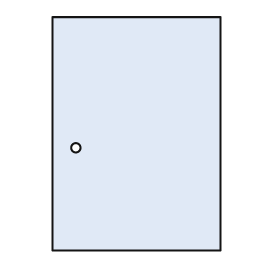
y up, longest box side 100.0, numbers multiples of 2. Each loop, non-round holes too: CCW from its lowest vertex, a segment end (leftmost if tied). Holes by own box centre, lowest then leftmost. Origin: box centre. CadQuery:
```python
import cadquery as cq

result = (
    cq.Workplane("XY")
    .moveTo(-36.0, -50.0)
    .lineTo(36.0, -50.0)
    .lineTo(36.0, 50.0)
    .lineTo(-36.0, 50.0)
    .close()
    .moveTo(-26.0, -6.0)
    .circle(2.0)
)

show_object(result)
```